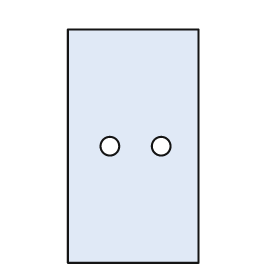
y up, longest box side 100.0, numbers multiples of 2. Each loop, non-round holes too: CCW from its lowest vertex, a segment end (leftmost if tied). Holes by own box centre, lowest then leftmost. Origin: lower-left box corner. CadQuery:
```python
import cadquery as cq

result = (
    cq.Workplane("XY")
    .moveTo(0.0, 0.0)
    .lineTo(56.0, 0.0)
    .lineTo(56.0, 100.0)
    .lineTo(0.0, 100.0)
    .close()
    .moveTo(18.0, 50.0)
    .circle(4.0)
    .moveTo(40.0, 50.0)
    .circle(4.0)
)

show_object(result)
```